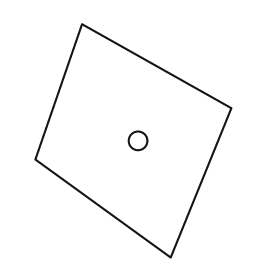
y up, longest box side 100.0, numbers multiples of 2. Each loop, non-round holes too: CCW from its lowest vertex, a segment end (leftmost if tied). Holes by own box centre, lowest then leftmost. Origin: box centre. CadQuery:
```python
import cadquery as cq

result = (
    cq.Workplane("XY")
    .moveTo(16.0, -50.0)
    .lineTo(42.0, 14.0)
    .lineTo(-22.0, 50.0)
    .lineTo(-42.0, -8.0)
    .close()
    .moveTo(2.0, 0.0)
    .circle(4.0)
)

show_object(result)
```